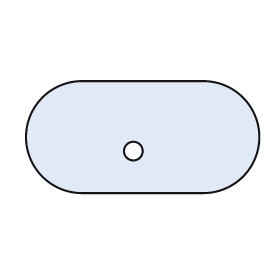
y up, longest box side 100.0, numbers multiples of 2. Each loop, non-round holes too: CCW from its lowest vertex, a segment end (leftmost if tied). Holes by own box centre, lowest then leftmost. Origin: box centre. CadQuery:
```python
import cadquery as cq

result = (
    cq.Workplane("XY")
    .moveTo(-26.0, -24.0)
    .lineTo(26.0, -24.0)
    .threePointArc((50.0, 0.0), (26.0, 24.0))
    .lineTo(-26.0, 24.0)
    .threePointArc((-50.0, 0.0), (-26.0, -24.0))
    .close()
    .moveTo(-4.0, -6.0)
    .circle(4.0)
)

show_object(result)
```